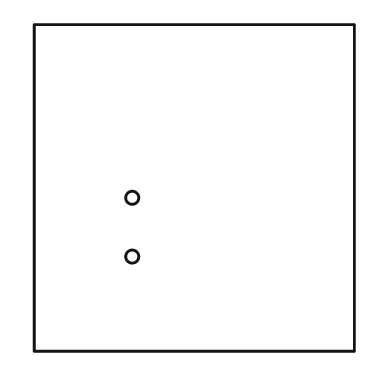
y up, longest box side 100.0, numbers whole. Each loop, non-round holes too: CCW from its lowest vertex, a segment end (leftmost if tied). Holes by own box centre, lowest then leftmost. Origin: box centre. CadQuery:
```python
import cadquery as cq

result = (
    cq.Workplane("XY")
    .moveTo(-49.0, -50.0)
    .lineTo(49.0, -50.0)
    .lineTo(49.0, 50.0)
    .lineTo(-49.0, 50.0)
    .close()
    .moveTo(-19.0, -21.0)
    .circle(2.0)
    .moveTo(-19.0, -3.0)
    .circle(2.0)
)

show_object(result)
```